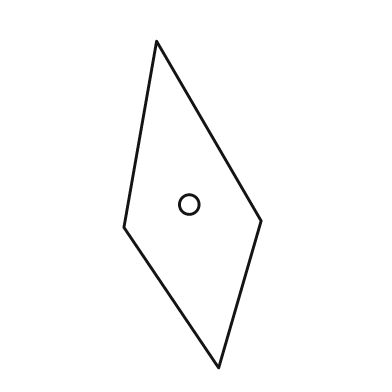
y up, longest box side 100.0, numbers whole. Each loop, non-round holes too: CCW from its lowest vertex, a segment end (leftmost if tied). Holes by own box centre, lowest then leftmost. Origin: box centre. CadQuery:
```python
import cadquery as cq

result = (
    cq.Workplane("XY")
    .moveTo(8.0, -50.0)
    .lineTo(21.0, -5.0)
    .lineTo(-11.0, 50.0)
    .lineTo(-21.0, -7.0)
    .close()
    .moveTo(-1.0, 0.0)
    .circle(3.0)
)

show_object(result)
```